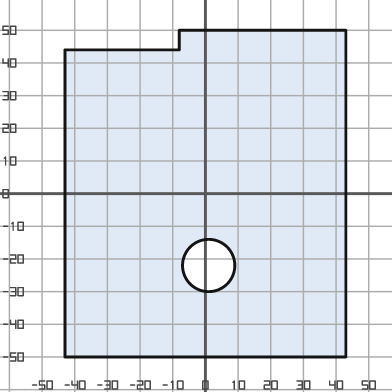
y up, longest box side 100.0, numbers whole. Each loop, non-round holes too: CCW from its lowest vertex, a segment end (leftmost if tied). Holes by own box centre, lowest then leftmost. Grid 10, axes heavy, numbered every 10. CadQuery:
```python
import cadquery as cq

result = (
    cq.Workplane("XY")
    .moveTo(-43.0, -50.0)
    .lineTo(43.0, -50.0)
    .lineTo(43.0, 50.0)
    .lineTo(-8.0, 50.0)
    .lineTo(-8.0, 44.0)
    .lineTo(-43.0, 44.0)
    .close()
    .moveTo(1.0, -22.0)
    .circle(8.0)
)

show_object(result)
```